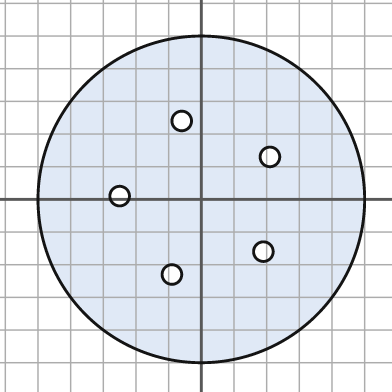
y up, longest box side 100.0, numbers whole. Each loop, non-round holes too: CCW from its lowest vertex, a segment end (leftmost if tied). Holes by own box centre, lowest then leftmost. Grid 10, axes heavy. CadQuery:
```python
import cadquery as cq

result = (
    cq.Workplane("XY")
    .moveTo(0.0, 0.0)
    .circle(50.0)
    .moveTo(-9.0, -23.0)
    .circle(3.0)
    .moveTo(19.0, -16.0)
    .circle(3.0)
    .moveTo(-25.0, 1.0)
    .circle(3.0)
    .moveTo(21.0, 13.0)
    .circle(3.0)
    .moveTo(-6.0, 24.0)
    .circle(3.0)
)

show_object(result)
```